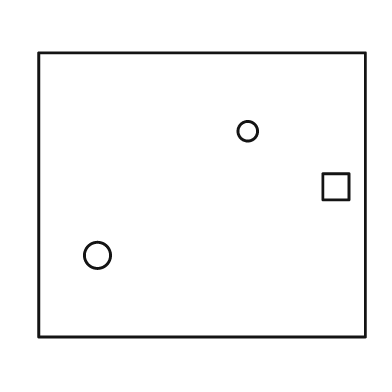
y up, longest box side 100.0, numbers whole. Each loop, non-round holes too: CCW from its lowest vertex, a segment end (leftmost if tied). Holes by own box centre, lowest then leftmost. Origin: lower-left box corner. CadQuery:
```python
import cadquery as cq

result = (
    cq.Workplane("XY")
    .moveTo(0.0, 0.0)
    .lineTo(100.0, 0.0)
    .lineTo(100.0, 87.0)
    .lineTo(0.0, 87.0)
    .close()
    .moveTo(18.0, 25.0)
    .circle(4.0)
    .moveTo(87.0, 42.0)
    .lineTo(95.0, 42.0)
    .lineTo(95.0, 50.0)
    .lineTo(87.0, 50.0)
    .close()
    .moveTo(64.0, 63.0)
    .circle(3.0)
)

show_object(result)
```